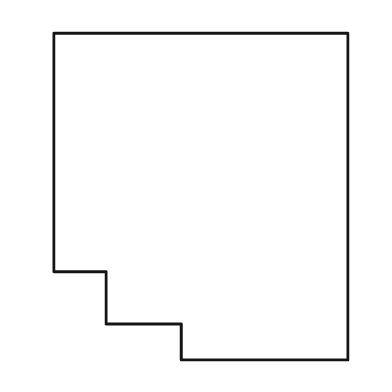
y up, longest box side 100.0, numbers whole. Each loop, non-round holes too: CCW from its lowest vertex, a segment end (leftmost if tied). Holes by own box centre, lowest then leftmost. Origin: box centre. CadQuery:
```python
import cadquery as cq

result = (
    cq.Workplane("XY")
    .moveTo(-6.0, -50.0)
    .lineTo(45.0, -50.0)
    .lineTo(45.0, 50.0)
    .lineTo(-45.0, 50.0)
    .lineTo(-45.0, -23.0)
    .lineTo(-29.0, -23.0)
    .lineTo(-29.0, -39.0)
    .lineTo(-6.0, -39.0)
    .close()
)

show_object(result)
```